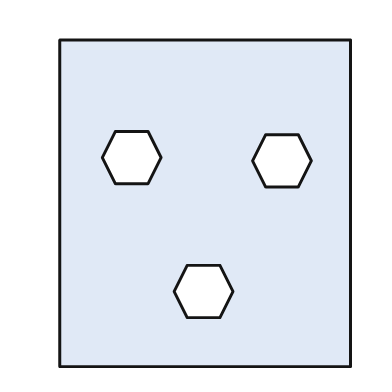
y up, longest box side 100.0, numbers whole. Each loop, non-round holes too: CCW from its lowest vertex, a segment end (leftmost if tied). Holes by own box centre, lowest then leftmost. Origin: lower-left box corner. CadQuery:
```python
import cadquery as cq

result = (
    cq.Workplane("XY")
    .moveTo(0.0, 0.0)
    .lineTo(89.0, 0.0)
    .lineTo(89.0, 100.0)
    .lineTo(0.0, 100.0)
    .close()
    .moveTo(39.0, 15.0)
    .lineTo(49.0, 15.0)
    .lineTo(53.0, 23.0)
    .lineTo(49.0, 31.0)
    .lineTo(39.0, 31.0)
    .lineTo(35.0, 23.0)
    .close()
    .moveTo(63.0, 55.0)
    .lineTo(73.0, 55.0)
    .lineTo(77.0, 63.0)
    .lineTo(73.0, 71.0)
    .lineTo(63.0, 71.0)
    .lineTo(59.0, 63.0)
    .close()
    .moveTo(17.0, 56.0)
    .lineTo(27.0, 56.0)
    .lineTo(31.0, 64.0)
    .lineTo(27.0, 72.0)
    .lineTo(17.0, 72.0)
    .lineTo(13.0, 64.0)
    .close()
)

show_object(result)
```